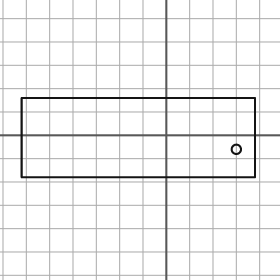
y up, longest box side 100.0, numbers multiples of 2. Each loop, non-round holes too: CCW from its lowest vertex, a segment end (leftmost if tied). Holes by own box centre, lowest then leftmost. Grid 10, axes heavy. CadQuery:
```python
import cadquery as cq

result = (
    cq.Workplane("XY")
    .moveTo(-62.0, -18.0)
    .lineTo(38.0, -18.0)
    .lineTo(38.0, 16.0)
    .lineTo(-62.0, 16.0)
    .close()
    .moveTo(30.0, -6.0)
    .circle(2.0)
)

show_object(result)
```